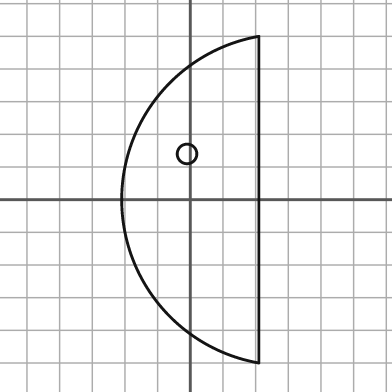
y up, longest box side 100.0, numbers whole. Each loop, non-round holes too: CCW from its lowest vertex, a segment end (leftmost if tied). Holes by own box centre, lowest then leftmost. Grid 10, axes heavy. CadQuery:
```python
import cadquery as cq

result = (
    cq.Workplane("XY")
    .moveTo(21.0, -50.0)
    .lineTo(21.0, 50.0)
    .threePointArc((-21.0, 0.0), (21.0, -50.0))
    .close()
    .moveTo(-1.0, 14.0)
    .circle(3.0)
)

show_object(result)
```